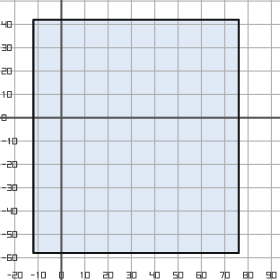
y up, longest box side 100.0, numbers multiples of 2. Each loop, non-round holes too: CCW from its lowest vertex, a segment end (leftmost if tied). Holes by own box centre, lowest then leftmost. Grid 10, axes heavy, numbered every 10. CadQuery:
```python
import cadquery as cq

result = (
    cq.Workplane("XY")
    .moveTo(-12.0, -58.0)
    .lineTo(76.0, -58.0)
    .lineTo(76.0, 42.0)
    .lineTo(-12.0, 42.0)
    .close()
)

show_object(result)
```